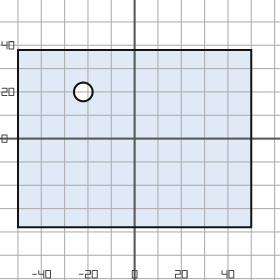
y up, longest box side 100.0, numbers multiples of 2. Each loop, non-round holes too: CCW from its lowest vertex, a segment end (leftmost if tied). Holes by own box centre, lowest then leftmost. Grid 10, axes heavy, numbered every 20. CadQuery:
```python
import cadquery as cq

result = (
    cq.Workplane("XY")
    .moveTo(-50.0, -38.0)
    .lineTo(50.0, -38.0)
    .lineTo(50.0, 38.0)
    .lineTo(-50.0, 38.0)
    .close()
    .moveTo(-22.0, 20.0)
    .circle(4.0)
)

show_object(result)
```